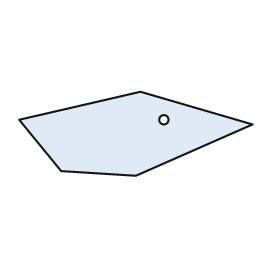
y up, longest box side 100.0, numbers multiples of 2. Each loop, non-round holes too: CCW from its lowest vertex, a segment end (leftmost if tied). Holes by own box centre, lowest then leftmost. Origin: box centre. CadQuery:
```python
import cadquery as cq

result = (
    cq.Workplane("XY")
    .moveTo(0.0, -18.0)
    .lineTo(50.0, 4.0)
    .lineTo(2.0, 18.0)
    .lineTo(-50.0, 6.0)
    .lineTo(-32.0, -16.0)
    .close()
    .moveTo(12.0, 6.0)
    .circle(2.0)
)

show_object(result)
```